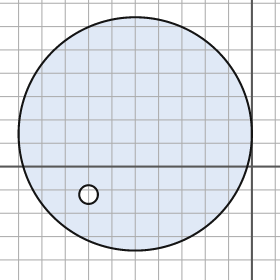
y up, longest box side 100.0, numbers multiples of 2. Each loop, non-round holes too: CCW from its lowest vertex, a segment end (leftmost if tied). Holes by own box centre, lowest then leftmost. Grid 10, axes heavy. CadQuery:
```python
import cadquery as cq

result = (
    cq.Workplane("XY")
    .moveTo(-50.0, 14.0)
    .circle(50.0)
    .moveTo(-70.0, -12.0)
    .circle(4.0)
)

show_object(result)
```